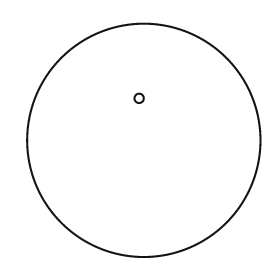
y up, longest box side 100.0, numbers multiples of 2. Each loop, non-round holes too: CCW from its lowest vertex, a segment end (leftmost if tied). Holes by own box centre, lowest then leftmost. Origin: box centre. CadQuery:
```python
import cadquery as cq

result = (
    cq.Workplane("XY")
    .moveTo(0.0, 0.0)
    .circle(50.0)
    .moveTo(-2.0, 18.0)
    .circle(2.0)
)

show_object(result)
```